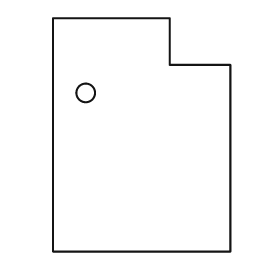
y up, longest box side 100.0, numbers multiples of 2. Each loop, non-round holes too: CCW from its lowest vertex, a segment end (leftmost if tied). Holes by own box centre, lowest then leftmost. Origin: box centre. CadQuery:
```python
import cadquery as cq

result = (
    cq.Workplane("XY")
    .moveTo(-38.0, -50.0)
    .lineTo(38.0, -50.0)
    .lineTo(38.0, 30.0)
    .lineTo(12.0, 30.0)
    .lineTo(12.0, 50.0)
    .lineTo(-38.0, 50.0)
    .close()
    .moveTo(-24.0, 18.0)
    .circle(4.0)
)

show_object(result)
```